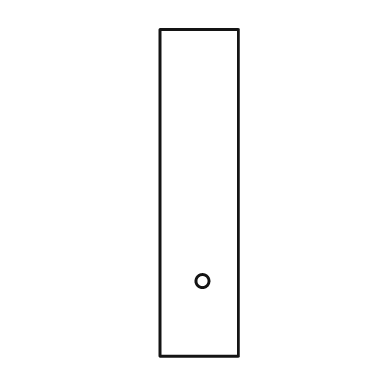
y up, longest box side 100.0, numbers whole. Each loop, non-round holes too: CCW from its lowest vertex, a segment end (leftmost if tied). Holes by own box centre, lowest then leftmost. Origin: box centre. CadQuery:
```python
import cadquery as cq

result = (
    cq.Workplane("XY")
    .moveTo(-12.0, -50.0)
    .lineTo(12.0, -50.0)
    .lineTo(12.0, 50.0)
    .lineTo(-12.0, 50.0)
    .close()
    .moveTo(1.0, -27.0)
    .circle(2.0)
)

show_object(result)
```